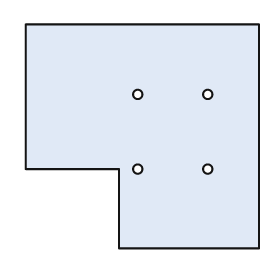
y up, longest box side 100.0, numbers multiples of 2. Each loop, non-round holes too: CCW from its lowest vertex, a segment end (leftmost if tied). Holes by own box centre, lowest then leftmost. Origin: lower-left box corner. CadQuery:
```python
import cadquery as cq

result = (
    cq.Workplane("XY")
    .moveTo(40.0, 0.0)
    .lineTo(100.0, 0.0)
    .lineTo(100.0, 96.0)
    .lineTo(0.0, 96.0)
    .lineTo(0.0, 34.0)
    .lineTo(40.0, 34.0)
    .close()
    .moveTo(48.0, 34.0)
    .circle(2.0)
    .moveTo(78.0, 34.0)
    .circle(2.0)
    .moveTo(48.0, 66.0)
    .circle(2.0)
    .moveTo(78.0, 66.0)
    .circle(2.0)
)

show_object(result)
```